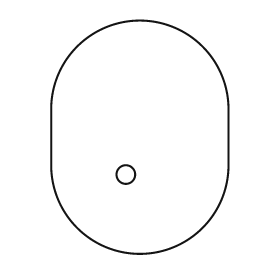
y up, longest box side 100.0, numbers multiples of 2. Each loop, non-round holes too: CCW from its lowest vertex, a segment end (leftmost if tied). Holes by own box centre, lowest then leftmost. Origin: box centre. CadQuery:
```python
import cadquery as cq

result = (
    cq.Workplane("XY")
    .moveTo(-38.0, -12.0)
    .threePointArc((0.0, -50.0), (38.0, -12.0))
    .lineTo(38.0, 12.0)
    .threePointArc((0.0, 50.0), (-38.0, 12.0))
    .close()
    .moveTo(-6.0, -16.0)
    .circle(4.0)
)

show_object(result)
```